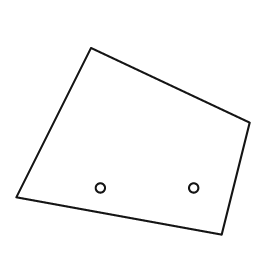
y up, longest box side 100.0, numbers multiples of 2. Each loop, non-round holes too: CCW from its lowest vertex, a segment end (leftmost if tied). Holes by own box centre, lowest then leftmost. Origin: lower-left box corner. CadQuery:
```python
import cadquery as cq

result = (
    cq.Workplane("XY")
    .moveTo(88.0, 0.0)
    .lineTo(100.0, 48.0)
    .lineTo(32.0, 80.0)
    .lineTo(0.0, 16.0)
    .close()
    .moveTo(36.0, 20.0)
    .circle(2.0)
    .moveTo(76.0, 20.0)
    .circle(2.0)
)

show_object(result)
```